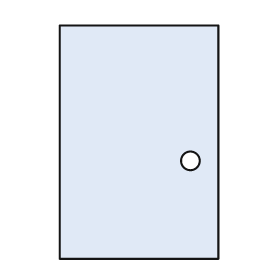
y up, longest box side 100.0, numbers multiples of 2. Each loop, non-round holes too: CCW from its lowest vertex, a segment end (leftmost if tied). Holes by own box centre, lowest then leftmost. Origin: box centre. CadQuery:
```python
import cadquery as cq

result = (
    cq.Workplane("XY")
    .moveTo(-34.0, -50.0)
    .lineTo(34.0, -50.0)
    .lineTo(34.0, 50.0)
    .lineTo(-34.0, 50.0)
    .close()
    .moveTo(22.0, -8.0)
    .circle(4.0)
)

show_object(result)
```